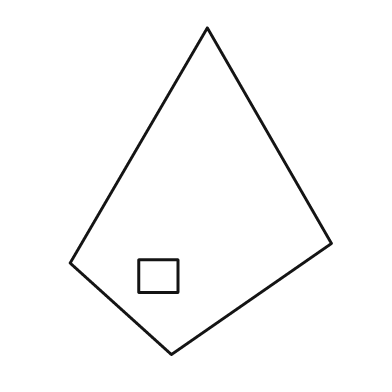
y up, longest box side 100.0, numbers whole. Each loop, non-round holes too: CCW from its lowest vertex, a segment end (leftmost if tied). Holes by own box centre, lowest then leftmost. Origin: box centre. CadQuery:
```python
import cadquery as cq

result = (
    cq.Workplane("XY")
    .moveTo(-9.0, -50.0)
    .lineTo(40.0, -16.0)
    .lineTo(2.0, 50.0)
    .lineTo(-40.0, -22.0)
    .close()
    .moveTo(-19.0, -31.0)
    .lineTo(-7.0, -31.0)
    .lineTo(-7.0, -21.0)
    .lineTo(-19.0, -21.0)
    .close()
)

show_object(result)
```